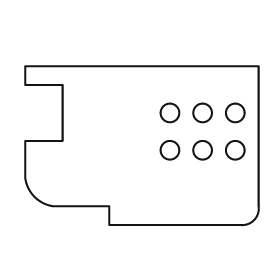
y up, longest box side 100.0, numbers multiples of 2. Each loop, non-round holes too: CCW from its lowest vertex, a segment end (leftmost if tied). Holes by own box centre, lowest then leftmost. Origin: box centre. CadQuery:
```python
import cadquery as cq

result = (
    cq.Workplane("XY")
    .moveTo(-14.0, -34.0)
    .lineTo(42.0, -34.0)
    .threePointArc((48.0, -32.0), (50.0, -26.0))
    .lineTo(50.0, 34.0)
    .lineTo(-50.0, 34.0)
    .lineTo(-50.0, 26.0)
    .lineTo(-34.0, 26.0)
    .lineTo(-34.0, 2.0)
    .lineTo(-50.0, 2.0)
    .lineTo(-50.0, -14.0)
    .threePointArc((-46.0, -22.0), (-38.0, -26.0))
    .lineTo(-14.0, -26.0)
    .close()
    .moveTo(12.0, -2.0)
    .circle(4.0)
    .moveTo(26.0, -2.0)
    .circle(4.0)
    .moveTo(40.0, -2.0)
    .circle(4.0)
    .moveTo(12.0, 14.0)
    .circle(4.0)
    .moveTo(26.0, 14.0)
    .circle(4.0)
    .moveTo(40.0, 14.0)
    .circle(4.0)
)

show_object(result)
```